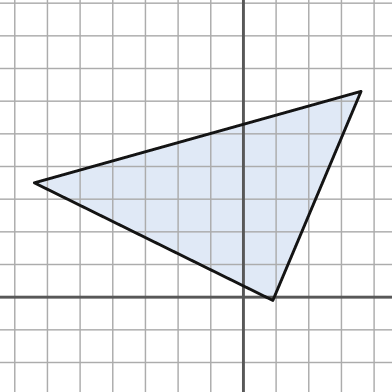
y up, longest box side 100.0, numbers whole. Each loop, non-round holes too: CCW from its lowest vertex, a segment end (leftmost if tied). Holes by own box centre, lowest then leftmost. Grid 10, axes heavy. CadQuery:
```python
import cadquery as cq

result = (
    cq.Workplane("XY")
    .moveTo(9.0, -1.0)
    .lineTo(36.0, 63.0)
    .lineTo(-64.0, 35.0)
    .close()
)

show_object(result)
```